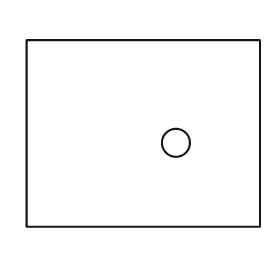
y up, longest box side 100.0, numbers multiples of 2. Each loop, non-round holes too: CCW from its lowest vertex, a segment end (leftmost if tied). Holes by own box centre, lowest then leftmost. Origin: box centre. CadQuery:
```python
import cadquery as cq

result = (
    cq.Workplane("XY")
    .moveTo(-50.0, -40.0)
    .lineTo(50.0, -40.0)
    .lineTo(50.0, 40.0)
    .lineTo(-50.0, 40.0)
    .close()
    .moveTo(14.0, -4.0)
    .circle(6.0)
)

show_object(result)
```